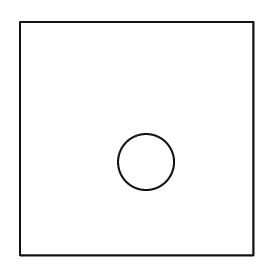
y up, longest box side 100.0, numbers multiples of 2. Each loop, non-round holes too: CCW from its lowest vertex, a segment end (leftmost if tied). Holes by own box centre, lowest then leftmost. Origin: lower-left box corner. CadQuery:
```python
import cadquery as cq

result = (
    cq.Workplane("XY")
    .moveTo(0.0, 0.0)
    .lineTo(100.0, 0.0)
    .lineTo(100.0, 100.0)
    .lineTo(0.0, 100.0)
    .close()
    .moveTo(54.0, 40.0)
    .circle(12.0)
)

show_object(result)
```